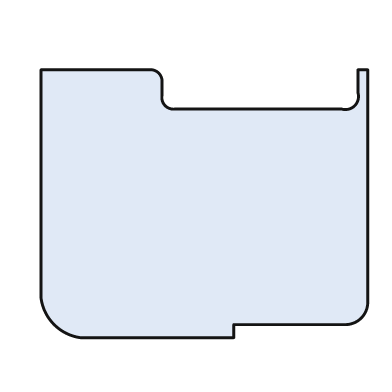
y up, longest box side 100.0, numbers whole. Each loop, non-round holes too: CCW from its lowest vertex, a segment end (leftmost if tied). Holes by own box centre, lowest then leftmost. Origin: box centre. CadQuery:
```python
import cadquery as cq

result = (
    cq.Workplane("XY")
    .moveTo(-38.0, -41.0)
    .lineTo(9.0, -41.0)
    .lineTo(9.0, -37.0)
    .lineTo(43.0, -37.0)
    .threePointArc((48.0, -35.0), (50.0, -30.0))
    .lineTo(50.0, 41.0)
    .lineTo(47.0, 41.0)
    .lineTo(47.0, 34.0)
    .threePointArc((46.0, 30.0), (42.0, 29.0))
    .lineTo(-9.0, 29.0)
    .threePointArc((-12.0, 30.0), (-13.0, 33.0))
    .lineTo(-13.0, 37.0)
    .threePointArc((-14.0, 40.0), (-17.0, 41.0))
    .lineTo(-50.0, 41.0)
    .lineTo(-50.0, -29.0)
    .threePointArc((-46.0, -37.0), (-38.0, -41.0))
    .close()
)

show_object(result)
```